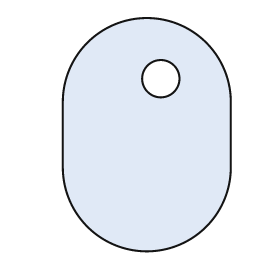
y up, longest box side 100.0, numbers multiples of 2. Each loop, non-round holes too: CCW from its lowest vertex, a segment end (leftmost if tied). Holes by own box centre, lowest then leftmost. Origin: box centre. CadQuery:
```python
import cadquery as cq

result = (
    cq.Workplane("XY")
    .moveTo(-36.0, -14.0)
    .threePointArc((0.0, -50.0), (36.0, -14.0))
    .lineTo(36.0, 14.0)
    .threePointArc((0.0, 50.0), (-36.0, 14.0))
    .close()
    .moveTo(6.0, 24.0)
    .circle(8.0)
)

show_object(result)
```